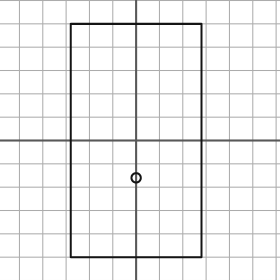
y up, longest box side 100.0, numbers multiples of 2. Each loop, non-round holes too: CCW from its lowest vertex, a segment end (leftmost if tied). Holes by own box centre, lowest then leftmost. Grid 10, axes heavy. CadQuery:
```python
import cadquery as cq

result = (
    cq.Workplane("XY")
    .moveTo(-28.0, -50.0)
    .lineTo(28.0, -50.0)
    .lineTo(28.0, 50.0)
    .lineTo(-28.0, 50.0)
    .close()
    .moveTo(0.0, -16.0)
    .circle(2.0)
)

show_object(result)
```